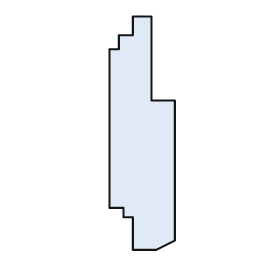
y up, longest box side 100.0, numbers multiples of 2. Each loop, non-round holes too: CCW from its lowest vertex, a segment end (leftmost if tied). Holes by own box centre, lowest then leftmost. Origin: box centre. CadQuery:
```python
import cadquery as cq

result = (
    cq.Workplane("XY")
    .moveTo(-4.0, -50.0)
    .lineTo(6.0, -50.0)
    .lineTo(14.0, -46.0)
    .lineTo(14.0, 14.0)
    .lineTo(4.0, 14.0)
    .lineTo(4.0, 50.0)
    .lineTo(-4.0, 50.0)
    .lineTo(-4.0, 42.0)
    .lineTo(-10.0, 42.0)
    .lineTo(-10.0, 36.0)
    .lineTo(-14.0, 36.0)
    .lineTo(-14.0, -32.0)
    .lineTo(-8.0, -32.0)
    .lineTo(-8.0, -36.0)
    .lineTo(-4.0, -36.0)
    .close()
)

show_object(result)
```